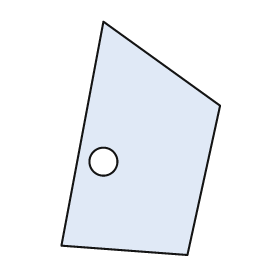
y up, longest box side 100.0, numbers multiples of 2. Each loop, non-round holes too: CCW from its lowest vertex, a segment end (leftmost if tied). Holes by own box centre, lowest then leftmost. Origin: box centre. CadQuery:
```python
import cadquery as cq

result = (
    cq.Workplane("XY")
    .moveTo(20.0, -50.0)
    .lineTo(34.0, 14.0)
    .lineTo(-16.0, 50.0)
    .lineTo(-34.0, -46.0)
    .close()
    .moveTo(-16.0, -10.0)
    .circle(6.0)
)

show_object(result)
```